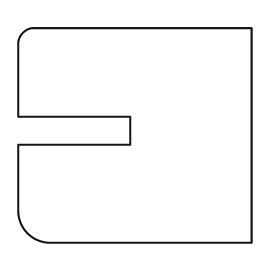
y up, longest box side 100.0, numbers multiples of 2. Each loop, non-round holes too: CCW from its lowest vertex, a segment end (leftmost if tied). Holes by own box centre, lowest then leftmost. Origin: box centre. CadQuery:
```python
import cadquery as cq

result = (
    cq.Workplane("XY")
    .moveTo(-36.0, -46.0)
    .lineTo(50.0, -46.0)
    .lineTo(50.0, 46.0)
    .lineTo(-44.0, 46.0)
    .threePointArc((-48.0, 44.0), (-50.0, 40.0))
    .lineTo(-50.0, 8.0)
    .lineTo(-2.0, 8.0)
    .lineTo(-2.0, -4.0)
    .lineTo(-50.0, -4.0)
    .lineTo(-50.0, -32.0)
    .threePointArc((-46.0, -42.0), (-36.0, -46.0))
    .close()
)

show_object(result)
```